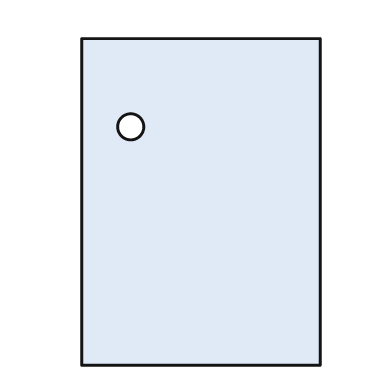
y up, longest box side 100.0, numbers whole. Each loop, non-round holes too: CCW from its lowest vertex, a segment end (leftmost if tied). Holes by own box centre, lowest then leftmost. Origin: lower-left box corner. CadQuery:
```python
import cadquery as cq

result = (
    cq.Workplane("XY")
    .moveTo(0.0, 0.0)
    .lineTo(73.0, 0.0)
    .lineTo(73.0, 100.0)
    .lineTo(0.0, 100.0)
    .close()
    .moveTo(15.0, 73.0)
    .circle(4.0)
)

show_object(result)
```